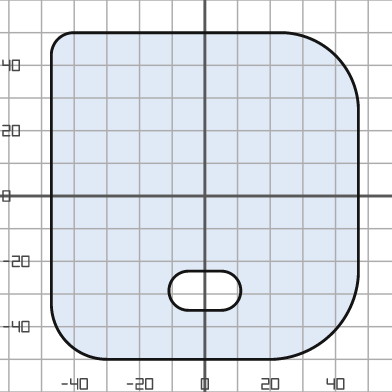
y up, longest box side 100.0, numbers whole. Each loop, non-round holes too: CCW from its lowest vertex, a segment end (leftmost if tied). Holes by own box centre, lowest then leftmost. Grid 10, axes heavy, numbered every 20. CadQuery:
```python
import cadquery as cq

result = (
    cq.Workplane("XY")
    .moveTo(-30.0, -50.0)
    .lineTo(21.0, -50.0)
    .threePointArc((39.0, -42.0), (47.0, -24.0))
    .lineTo(47.0, 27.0)
    .threePointArc((40.0, 43.0), (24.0, 50.0))
    .lineTo(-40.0, 50.0)
    .threePointArc((-45.0, 48.0), (-47.0, 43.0))
    .lineTo(-47.0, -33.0)
    .threePointArc((-42.0, -45.0), (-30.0, -50.0))
    .close()
    .moveTo(-5.0, -35.0)
    .lineTo(5.0, -35.0)
    .threePointArc((11.0, -29.0), (5.0, -23.0))
    .lineTo(-5.0, -23.0)
    .threePointArc((-11.0, -29.0), (-5.0, -35.0))
    .close()
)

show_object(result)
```